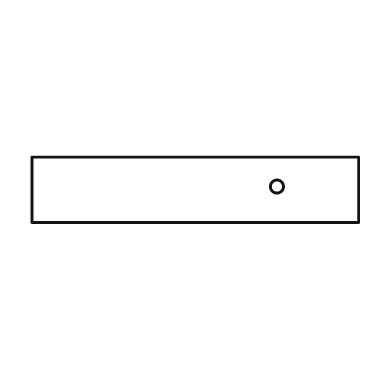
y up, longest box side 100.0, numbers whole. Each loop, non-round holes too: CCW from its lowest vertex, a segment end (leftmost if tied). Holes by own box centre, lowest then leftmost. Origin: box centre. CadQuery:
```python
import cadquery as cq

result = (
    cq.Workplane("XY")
    .moveTo(-50.0, -10.0)
    .lineTo(50.0, -10.0)
    .lineTo(50.0, 10.0)
    .lineTo(-50.0, 10.0)
    .close()
    .moveTo(25.0, 1.0)
    .circle(2.0)
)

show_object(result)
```